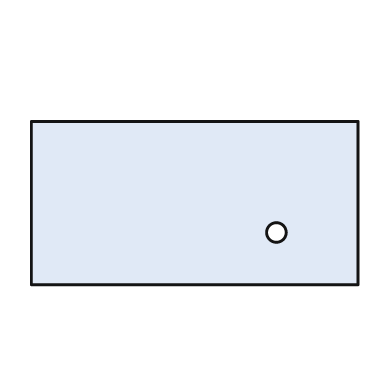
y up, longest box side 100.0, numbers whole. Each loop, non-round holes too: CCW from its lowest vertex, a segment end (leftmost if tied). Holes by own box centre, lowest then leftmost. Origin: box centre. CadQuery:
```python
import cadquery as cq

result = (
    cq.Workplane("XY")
    .moveTo(-50.0, -25.0)
    .lineTo(50.0, -25.0)
    .lineTo(50.0, 25.0)
    .lineTo(-50.0, 25.0)
    .close()
    .moveTo(25.0, -9.0)
    .circle(3.0)
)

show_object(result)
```